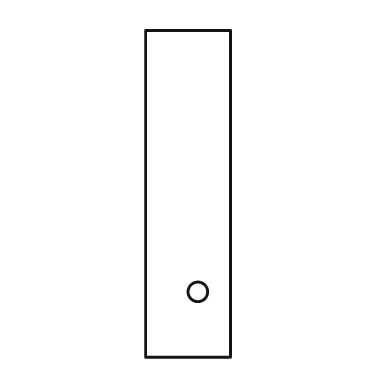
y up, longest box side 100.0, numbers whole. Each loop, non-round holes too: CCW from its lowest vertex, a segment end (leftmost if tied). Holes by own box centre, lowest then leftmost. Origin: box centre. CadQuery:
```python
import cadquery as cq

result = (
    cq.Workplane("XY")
    .moveTo(-13.0, -50.0)
    .lineTo(13.0, -50.0)
    .lineTo(13.0, 50.0)
    .lineTo(-13.0, 50.0)
    .close()
    .moveTo(3.0, -30.0)
    .circle(3.0)
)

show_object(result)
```